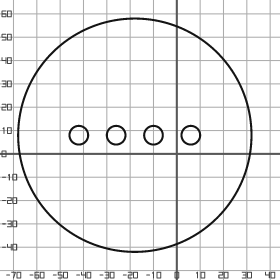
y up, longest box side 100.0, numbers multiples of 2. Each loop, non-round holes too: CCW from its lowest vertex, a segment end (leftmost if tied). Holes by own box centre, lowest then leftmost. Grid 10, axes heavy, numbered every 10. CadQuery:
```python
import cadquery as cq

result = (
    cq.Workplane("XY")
    .moveTo(-18.0, 8.0)
    .circle(50.0)
    .moveTo(-42.0, 8.0)
    .circle(4.0)
    .moveTo(-26.0, 8.0)
    .circle(4.0)
    .moveTo(-10.0, 8.0)
    .circle(4.0)
    .moveTo(6.0, 8.0)
    .circle(4.0)
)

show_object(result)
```